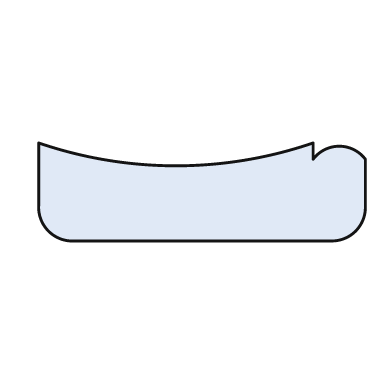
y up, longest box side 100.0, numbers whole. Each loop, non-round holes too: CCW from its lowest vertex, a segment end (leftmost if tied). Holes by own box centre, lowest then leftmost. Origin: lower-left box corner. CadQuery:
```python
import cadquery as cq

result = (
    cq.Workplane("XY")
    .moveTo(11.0, 0.0)
    .lineTo(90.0, 0.0)
    .threePointArc((97.0, 3.0), (100.0, 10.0))
    .lineTo(100.0, 25.0)
    .threePointArc((92.0, 29.0), (84.0, 25.0))
    .lineTo(84.0, 30.0)
    .threePointArc((42.0, 23.0), (0.0, 30.0))
    .lineTo(0.0, 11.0)
    .threePointArc((3.0, 3.0), (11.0, 0.0))
    .close()
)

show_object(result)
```